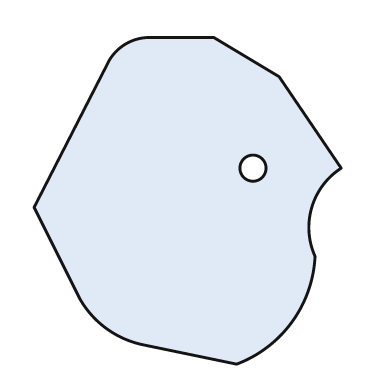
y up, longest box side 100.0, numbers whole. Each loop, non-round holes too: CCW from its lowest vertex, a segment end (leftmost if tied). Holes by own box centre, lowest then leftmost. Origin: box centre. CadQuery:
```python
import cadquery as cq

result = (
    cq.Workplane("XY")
    .moveTo(15.0, -50.0)
    .threePointArc((32.0, -37.0), (39.0, -17.0))
    .threePointArc((38.0, -2.0), (47.0, 10.0))
    .lineTo(28.0, 38.0)
    .lineTo(8.0, 50.0)
    .lineTo(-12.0, 50.0)
    .threePointArc((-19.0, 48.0), (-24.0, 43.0))
    .lineTo(-47.0, -2.0)
    .lineTo(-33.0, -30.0)
    .threePointArc((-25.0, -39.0), (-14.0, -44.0))
    .close()
    .moveTo(20.0, 10.0)
    .circle(4.0)
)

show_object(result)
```